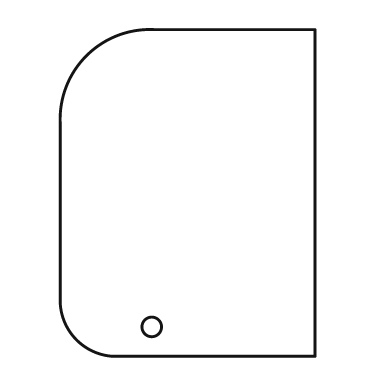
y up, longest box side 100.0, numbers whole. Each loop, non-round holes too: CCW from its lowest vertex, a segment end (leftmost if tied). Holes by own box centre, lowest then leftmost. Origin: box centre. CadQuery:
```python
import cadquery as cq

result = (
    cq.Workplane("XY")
    .moveTo(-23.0, -50.0)
    .lineTo(39.0, -50.0)
    .lineTo(39.0, 50.0)
    .lineTo(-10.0, 50.0)
    .threePointArc((-31.0, 42.0), (-39.0, 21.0))
    .lineTo(-39.0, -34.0)
    .threePointArc((-34.0, -45.0), (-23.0, -50.0))
    .close()
    .moveTo(-11.0, -41.0)
    .circle(3.0)
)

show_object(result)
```